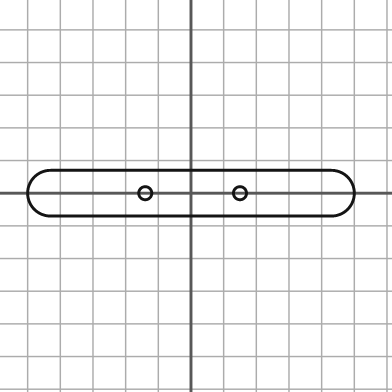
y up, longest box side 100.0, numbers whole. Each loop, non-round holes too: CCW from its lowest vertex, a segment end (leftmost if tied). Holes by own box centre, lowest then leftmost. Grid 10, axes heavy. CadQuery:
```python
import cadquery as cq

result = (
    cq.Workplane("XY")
    .moveTo(-43.0, -7.0)
    .lineTo(43.0, -7.0)
    .threePointArc((50.0, 0.0), (43.0, 7.0))
    .lineTo(-43.0, 7.0)
    .threePointArc((-50.0, 0.0), (-43.0, -7.0))
    .close()
    .moveTo(-14.0, 0.0)
    .circle(2.0)
    .moveTo(15.0, 0.0)
    .circle(2.0)
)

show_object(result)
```